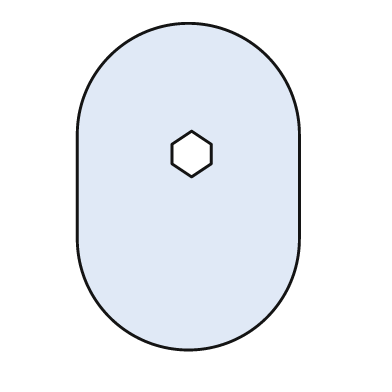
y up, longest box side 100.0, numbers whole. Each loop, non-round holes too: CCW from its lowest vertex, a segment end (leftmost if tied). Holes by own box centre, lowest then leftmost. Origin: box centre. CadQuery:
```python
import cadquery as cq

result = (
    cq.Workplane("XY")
    .moveTo(-34.0, -16.0)
    .threePointArc((0.0, -50.0), (34.0, -16.0))
    .lineTo(34.0, 16.0)
    .threePointArc((0.0, 50.0), (-34.0, 16.0))
    .close()
    .moveTo(1.0, 3.0)
    .lineTo(7.0, 7.0)
    .lineTo(7.0, 13.0)
    .lineTo(1.0, 17.0)
    .lineTo(-5.0, 13.0)
    .lineTo(-5.0, 7.0)
    .close()
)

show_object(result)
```